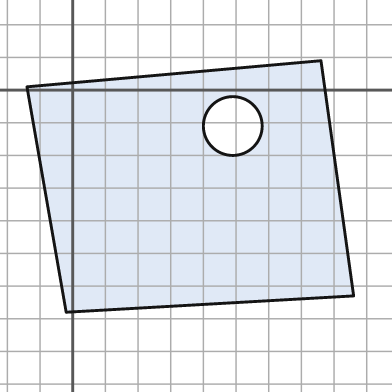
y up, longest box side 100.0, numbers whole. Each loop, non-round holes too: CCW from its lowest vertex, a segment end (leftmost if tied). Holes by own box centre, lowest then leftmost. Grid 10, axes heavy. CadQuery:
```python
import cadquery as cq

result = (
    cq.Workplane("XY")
    .moveTo(-2.0, -68.0)
    .lineTo(86.0, -63.0)
    .lineTo(76.0, 9.0)
    .lineTo(-14.0, 1.0)
    .close()
    .moveTo(49.0, -11.0)
    .circle(9.0)
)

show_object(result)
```